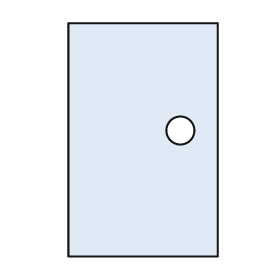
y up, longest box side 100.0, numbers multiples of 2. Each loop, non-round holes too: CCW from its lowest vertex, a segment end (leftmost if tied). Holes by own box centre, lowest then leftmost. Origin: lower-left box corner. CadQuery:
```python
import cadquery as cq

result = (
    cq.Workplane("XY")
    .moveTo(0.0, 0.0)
    .lineTo(64.0, 0.0)
    .lineTo(64.0, 100.0)
    .lineTo(0.0, 100.0)
    .close()
    .moveTo(48.0, 54.0)
    .circle(6.0)
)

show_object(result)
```